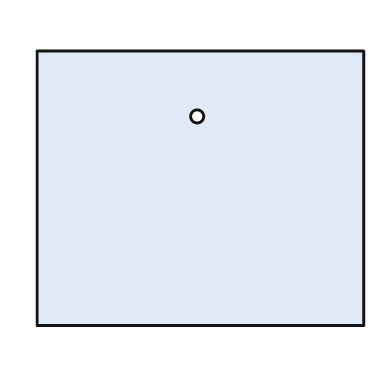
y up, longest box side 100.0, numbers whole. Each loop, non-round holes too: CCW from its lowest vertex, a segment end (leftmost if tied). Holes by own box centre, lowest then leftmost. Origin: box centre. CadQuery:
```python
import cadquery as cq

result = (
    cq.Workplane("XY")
    .moveTo(-50.0, -42.0)
    .lineTo(50.0, -42.0)
    .lineTo(50.0, 42.0)
    .lineTo(-50.0, 42.0)
    .close()
    .moveTo(-1.0, 22.0)
    .circle(2.0)
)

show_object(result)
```